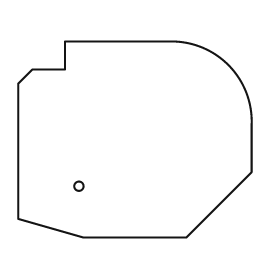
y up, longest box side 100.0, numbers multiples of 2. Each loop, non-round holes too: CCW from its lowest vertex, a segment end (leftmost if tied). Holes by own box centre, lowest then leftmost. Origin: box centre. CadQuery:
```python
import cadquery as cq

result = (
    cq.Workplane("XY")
    .moveTo(-22.0, -42.0)
    .lineTo(22.0, -42.0)
    .lineTo(50.0, -14.0)
    .lineTo(50.0, 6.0)
    .threePointArc((40.0, 32.0), (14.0, 42.0))
    .lineTo(-30.0, 42.0)
    .lineTo(-30.0, 30.0)
    .lineTo(-44.0, 30.0)
    .lineTo(-50.0, 24.0)
    .lineTo(-50.0, -34.0)
    .close()
    .moveTo(-24.0, -20.0)
    .circle(2.0)
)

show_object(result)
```